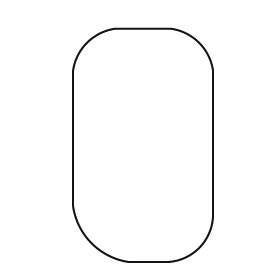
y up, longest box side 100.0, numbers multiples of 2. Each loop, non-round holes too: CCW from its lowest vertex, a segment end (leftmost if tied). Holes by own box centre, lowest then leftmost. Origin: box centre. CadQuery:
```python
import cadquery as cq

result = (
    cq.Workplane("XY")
    .moveTo(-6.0, -50.0)
    .lineTo(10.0, -50.0)
    .threePointArc((24.0, -44.0), (30.0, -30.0))
    .lineTo(30.0, 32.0)
    .threePointArc((24.0, 44.0), (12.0, 50.0))
    .lineTo(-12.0, 50.0)
    .threePointArc((-24.0, 44.0), (-30.0, 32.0))
    .lineTo(-30.0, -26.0)
    .threePointArc((-22.0, -42.0), (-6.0, -50.0))
    .close()
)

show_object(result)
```